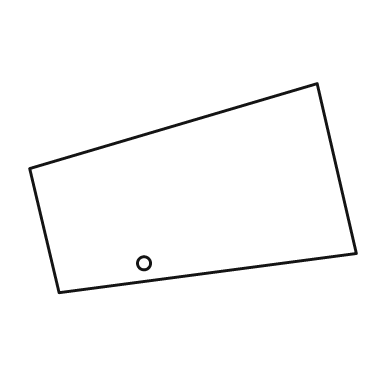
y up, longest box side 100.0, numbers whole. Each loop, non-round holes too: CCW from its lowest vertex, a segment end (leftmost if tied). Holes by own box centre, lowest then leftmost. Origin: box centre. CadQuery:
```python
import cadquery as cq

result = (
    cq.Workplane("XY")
    .moveTo(-41.0, -32.0)
    .lineTo(50.0, -20.0)
    .lineTo(38.0, 32.0)
    .lineTo(-50.0, 6.0)
    .close()
    .moveTo(-15.0, -23.0)
    .circle(2.0)
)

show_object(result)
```